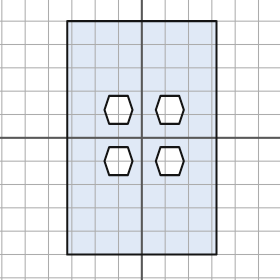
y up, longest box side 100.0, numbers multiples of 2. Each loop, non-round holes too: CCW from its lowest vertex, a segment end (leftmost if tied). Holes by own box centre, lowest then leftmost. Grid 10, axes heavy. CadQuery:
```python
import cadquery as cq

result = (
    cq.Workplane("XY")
    .moveTo(-32.0, -50.0)
    .lineTo(32.0, -50.0)
    .lineTo(32.0, 50.0)
    .lineTo(-32.0, 50.0)
    .close()
    .moveTo(-14.0, -16.0)
    .lineTo(-6.0, -16.0)
    .lineTo(-4.0, -10.0)
    .lineTo(-6.0, -4.0)
    .lineTo(-14.0, -4.0)
    .lineTo(-16.0, -10.0)
    .close()
    .moveTo(8.0, -16.0)
    .lineTo(16.0, -16.0)
    .lineTo(18.0, -10.0)
    .lineTo(16.0, -4.0)
    .lineTo(8.0, -4.0)
    .lineTo(6.0, -10.0)
    .close()
    .moveTo(-14.0, 6.0)
    .lineTo(-6.0, 6.0)
    .lineTo(-4.0, 12.0)
    .lineTo(-6.0, 18.0)
    .lineTo(-14.0, 18.0)
    .lineTo(-16.0, 12.0)
    .close()
    .moveTo(8.0, 6.0)
    .lineTo(16.0, 6.0)
    .lineTo(18.0, 12.0)
    .lineTo(16.0, 18.0)
    .lineTo(8.0, 18.0)
    .lineTo(6.0, 12.0)
    .close()
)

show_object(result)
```